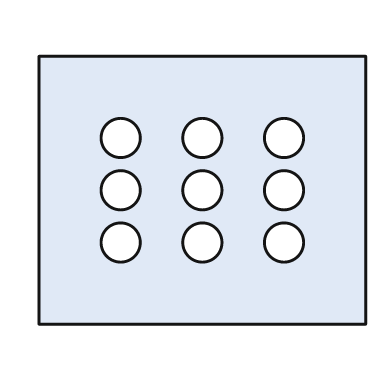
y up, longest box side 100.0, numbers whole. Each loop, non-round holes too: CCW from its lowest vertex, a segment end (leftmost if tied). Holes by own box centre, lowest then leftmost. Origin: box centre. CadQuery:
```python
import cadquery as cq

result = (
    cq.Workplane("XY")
    .moveTo(-50.0, -41.0)
    .lineTo(50.0, -41.0)
    .lineTo(50.0, 41.0)
    .lineTo(-50.0, 41.0)
    .close()
    .moveTo(-25.0, -16.0)
    .circle(6.0)
    .moveTo(0.0, -16.0)
    .circle(6.0)
    .moveTo(25.0, -16.0)
    .circle(6.0)
    .moveTo(-25.0, 0.0)
    .circle(6.0)
    .moveTo(0.0, 0.0)
    .circle(6.0)
    .moveTo(25.0, 0.0)
    .circle(6.0)
    .moveTo(-25.0, 16.0)
    .circle(6.0)
    .moveTo(0.0, 16.0)
    .circle(6.0)
    .moveTo(25.0, 16.0)
    .circle(6.0)
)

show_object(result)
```